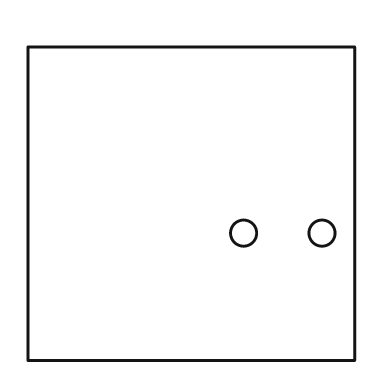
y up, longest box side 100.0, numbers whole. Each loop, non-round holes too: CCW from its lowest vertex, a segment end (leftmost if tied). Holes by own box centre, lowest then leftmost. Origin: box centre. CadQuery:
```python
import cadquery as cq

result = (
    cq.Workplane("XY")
    .moveTo(-50.0, -48.0)
    .lineTo(50.0, -48.0)
    .lineTo(50.0, 48.0)
    .lineTo(-50.0, 48.0)
    .close()
    .moveTo(16.0, -9.0)
    .circle(4.0)
    .moveTo(40.0, -9.0)
    .circle(4.0)
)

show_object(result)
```